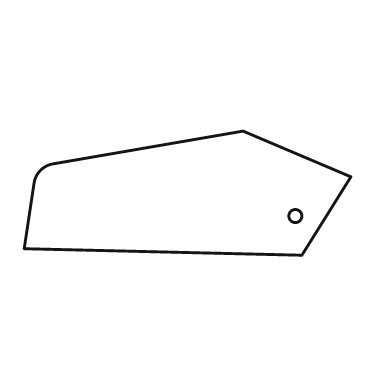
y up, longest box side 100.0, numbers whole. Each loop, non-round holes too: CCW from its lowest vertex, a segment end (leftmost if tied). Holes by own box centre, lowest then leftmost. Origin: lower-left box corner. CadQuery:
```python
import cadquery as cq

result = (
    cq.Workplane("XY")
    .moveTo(85.0, 0.0)
    .lineTo(100.0, 24.0)
    .lineTo(67.0, 38.0)
    .lineTo(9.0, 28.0)
    .threePointArc((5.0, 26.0), (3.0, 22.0))
    .lineTo(0.0, 2.0)
    .close()
    .moveTo(83.0, 12.0)
    .circle(2.0)
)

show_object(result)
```